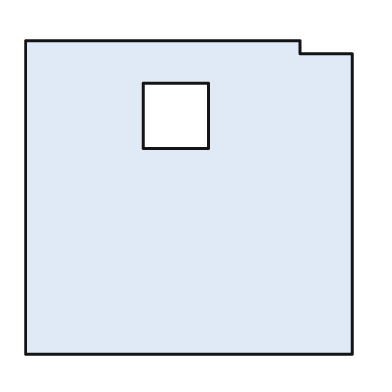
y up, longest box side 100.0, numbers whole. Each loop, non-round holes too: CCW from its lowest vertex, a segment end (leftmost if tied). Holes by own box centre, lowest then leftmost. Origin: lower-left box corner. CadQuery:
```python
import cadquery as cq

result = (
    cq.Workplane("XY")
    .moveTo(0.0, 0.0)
    .lineTo(100.0, 0.0)
    .lineTo(100.0, 92.0)
    .lineTo(84.0, 92.0)
    .lineTo(84.0, 96.0)
    .lineTo(0.0, 96.0)
    .close()
    .moveTo(36.0, 63.0)
    .lineTo(56.0, 63.0)
    .lineTo(56.0, 83.0)
    .lineTo(36.0, 83.0)
    .close()
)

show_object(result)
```